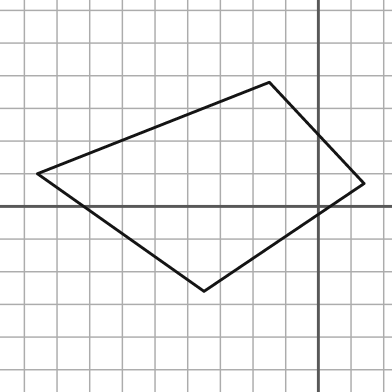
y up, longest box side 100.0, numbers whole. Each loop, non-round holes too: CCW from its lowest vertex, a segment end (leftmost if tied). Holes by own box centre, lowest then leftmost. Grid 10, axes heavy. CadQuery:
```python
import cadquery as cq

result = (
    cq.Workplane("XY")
    .moveTo(-35.0, -26.0)
    .lineTo(14.0, 7.0)
    .lineTo(-15.0, 38.0)
    .lineTo(-86.0, 10.0)
    .close()
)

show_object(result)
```